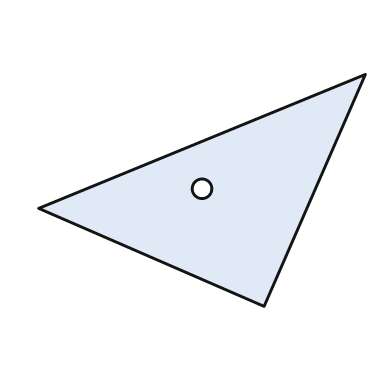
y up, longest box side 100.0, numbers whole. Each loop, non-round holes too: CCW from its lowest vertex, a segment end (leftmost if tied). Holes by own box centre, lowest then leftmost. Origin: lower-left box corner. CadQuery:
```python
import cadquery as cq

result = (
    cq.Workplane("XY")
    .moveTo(69.0, 0.0)
    .lineTo(100.0, 71.0)
    .lineTo(0.0, 30.0)
    .close()
    .moveTo(50.0, 36.0)
    .circle(3.0)
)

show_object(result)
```